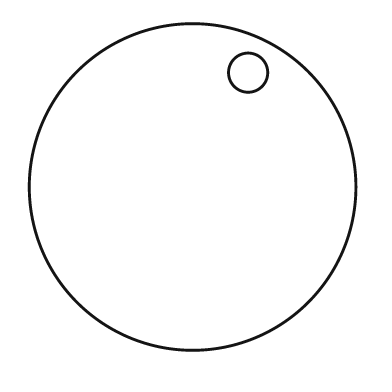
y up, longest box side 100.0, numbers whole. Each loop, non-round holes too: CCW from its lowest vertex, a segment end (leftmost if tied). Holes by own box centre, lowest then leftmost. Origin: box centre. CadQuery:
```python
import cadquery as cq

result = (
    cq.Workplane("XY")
    .moveTo(0.0, 0.0)
    .circle(50.0)
    .moveTo(17.0, 35.0)
    .circle(6.0)
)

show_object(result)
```